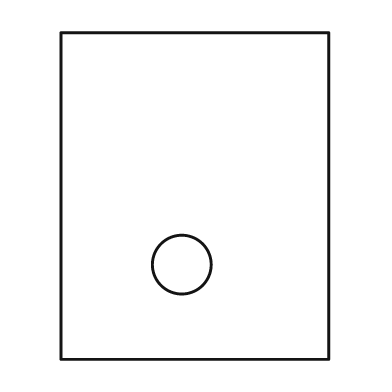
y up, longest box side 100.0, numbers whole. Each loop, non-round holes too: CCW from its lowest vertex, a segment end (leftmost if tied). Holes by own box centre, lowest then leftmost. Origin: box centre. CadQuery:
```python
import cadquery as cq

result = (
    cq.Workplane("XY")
    .moveTo(-41.0, -50.0)
    .lineTo(41.0, -50.0)
    .lineTo(41.0, 50.0)
    .lineTo(-41.0, 50.0)
    .close()
    .moveTo(-4.0, -21.0)
    .circle(9.0)
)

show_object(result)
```